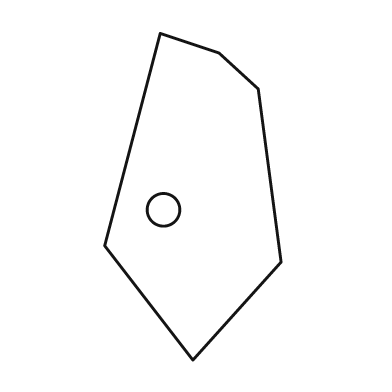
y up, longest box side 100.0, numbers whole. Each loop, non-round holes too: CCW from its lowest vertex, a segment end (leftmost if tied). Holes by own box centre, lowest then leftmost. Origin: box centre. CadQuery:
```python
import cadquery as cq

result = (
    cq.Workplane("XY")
    .moveTo(0.0, -50.0)
    .lineTo(27.0, -20.0)
    .lineTo(20.0, 33.0)
    .lineTo(8.0, 44.0)
    .lineTo(-10.0, 50.0)
    .lineTo(-27.0, -15.0)
    .close()
    .moveTo(-9.0, -4.0)
    .circle(5.0)
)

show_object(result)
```